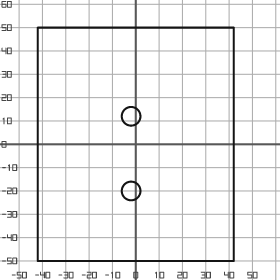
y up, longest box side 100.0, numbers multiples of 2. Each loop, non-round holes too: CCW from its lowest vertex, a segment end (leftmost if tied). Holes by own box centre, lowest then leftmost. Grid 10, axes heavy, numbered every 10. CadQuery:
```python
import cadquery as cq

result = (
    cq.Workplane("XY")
    .moveTo(-42.0, -50.0)
    .lineTo(42.0, -50.0)
    .lineTo(42.0, 50.0)
    .lineTo(-42.0, 50.0)
    .close()
    .moveTo(-2.0, -20.0)
    .circle(4.0)
    .moveTo(-2.0, 12.0)
    .circle(4.0)
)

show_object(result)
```